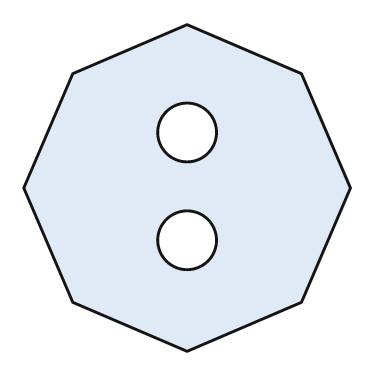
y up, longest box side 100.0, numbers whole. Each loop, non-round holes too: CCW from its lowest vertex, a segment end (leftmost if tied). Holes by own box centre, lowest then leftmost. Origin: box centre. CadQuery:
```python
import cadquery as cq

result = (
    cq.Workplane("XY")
    .moveTo(0.0, -50.0)
    .lineTo(35.0, -35.0)
    .lineTo(50.0, 0.0)
    .lineTo(35.0, 35.0)
    .lineTo(0.0, 50.0)
    .lineTo(-35.0, 35.0)
    .lineTo(-50.0, 0.0)
    .lineTo(-35.0, -35.0)
    .close()
    .moveTo(0.0, -16.0)
    .circle(9.0)
    .moveTo(0.0, 17.0)
    .circle(9.0)
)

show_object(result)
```